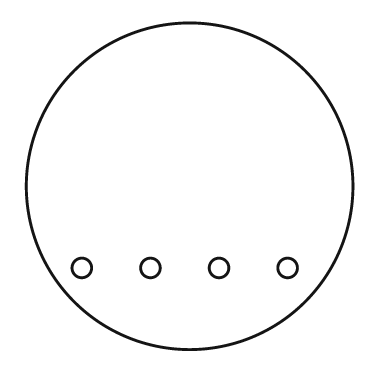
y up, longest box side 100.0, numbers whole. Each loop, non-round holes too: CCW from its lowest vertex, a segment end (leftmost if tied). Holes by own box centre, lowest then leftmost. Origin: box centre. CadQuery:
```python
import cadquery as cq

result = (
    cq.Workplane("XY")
    .moveTo(0.0, 0.0)
    .circle(50.0)
    .moveTo(-33.0, -25.0)
    .circle(3.0)
    .moveTo(-12.0, -25.0)
    .circle(3.0)
    .moveTo(9.0, -25.0)
    .circle(3.0)
    .moveTo(30.0, -25.0)
    .circle(3.0)
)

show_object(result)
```